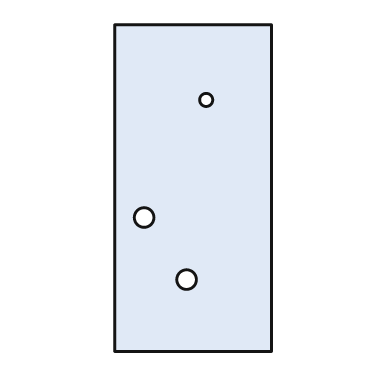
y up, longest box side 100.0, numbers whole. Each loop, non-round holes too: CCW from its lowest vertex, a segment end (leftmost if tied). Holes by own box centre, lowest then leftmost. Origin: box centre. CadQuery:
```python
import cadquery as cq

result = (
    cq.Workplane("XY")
    .moveTo(-24.0, -50.0)
    .lineTo(24.0, -50.0)
    .lineTo(24.0, 50.0)
    .lineTo(-24.0, 50.0)
    .close()
    .moveTo(-2.0, -28.0)
    .circle(3.0)
    .moveTo(-15.0, -9.0)
    .circle(3.0)
    .moveTo(4.0, 27.0)
    .circle(2.0)
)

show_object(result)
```